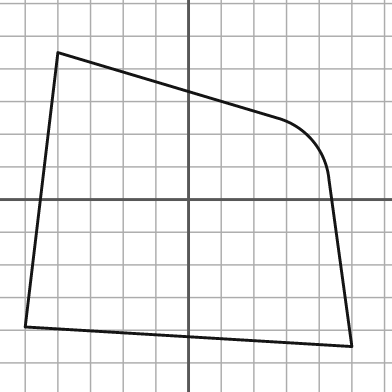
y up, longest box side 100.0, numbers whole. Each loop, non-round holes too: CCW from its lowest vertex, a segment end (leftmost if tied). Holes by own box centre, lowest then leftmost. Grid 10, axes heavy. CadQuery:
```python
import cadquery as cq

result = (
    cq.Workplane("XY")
    .moveTo(50.0, -45.0)
    .lineTo(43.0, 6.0)
    .threePointArc((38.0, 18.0), (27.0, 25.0))
    .lineTo(-40.0, 45.0)
    .lineTo(-50.0, -39.0)
    .close()
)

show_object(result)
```